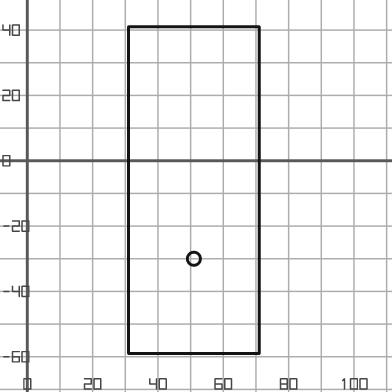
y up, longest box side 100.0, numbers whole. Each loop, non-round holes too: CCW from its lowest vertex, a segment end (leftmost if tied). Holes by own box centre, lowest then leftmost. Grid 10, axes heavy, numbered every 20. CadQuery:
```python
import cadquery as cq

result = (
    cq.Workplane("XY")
    .moveTo(31.0, -59.0)
    .lineTo(71.0, -59.0)
    .lineTo(71.0, 41.0)
    .lineTo(31.0, 41.0)
    .close()
    .moveTo(51.0, -30.0)
    .circle(2.0)
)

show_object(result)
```